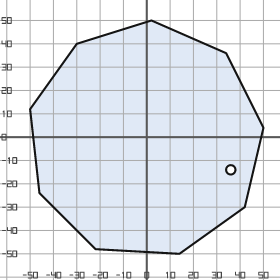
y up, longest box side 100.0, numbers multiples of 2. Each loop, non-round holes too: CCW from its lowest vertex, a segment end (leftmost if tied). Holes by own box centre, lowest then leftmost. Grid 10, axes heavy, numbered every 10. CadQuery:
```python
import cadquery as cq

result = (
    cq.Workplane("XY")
    .moveTo(14.0, -50.0)
    .lineTo(42.0, -30.0)
    .lineTo(50.0, 4.0)
    .lineTo(34.0, 36.0)
    .lineTo(2.0, 50.0)
    .lineTo(-30.0, 40.0)
    .lineTo(-50.0, 12.0)
    .lineTo(-46.0, -24.0)
    .lineTo(-22.0, -48.0)
    .close()
    .moveTo(36.0, -14.0)
    .circle(2.0)
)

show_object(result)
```